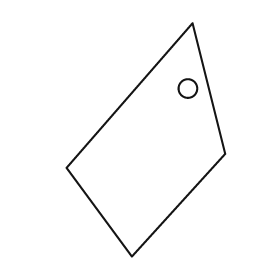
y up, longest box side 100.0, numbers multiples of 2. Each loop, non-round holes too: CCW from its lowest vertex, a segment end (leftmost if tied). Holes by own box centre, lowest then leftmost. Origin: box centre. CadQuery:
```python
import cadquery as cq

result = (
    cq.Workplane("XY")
    .moveTo(-6.0, -50.0)
    .lineTo(34.0, -6.0)
    .lineTo(20.0, 50.0)
    .lineTo(-34.0, -12.0)
    .close()
    .moveTo(18.0, 22.0)
    .circle(4.0)
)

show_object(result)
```